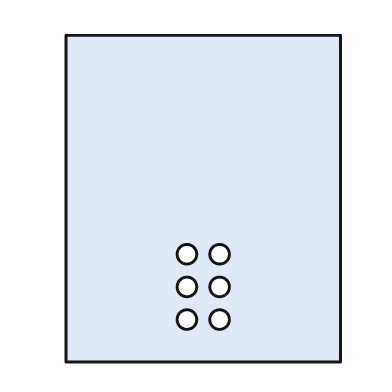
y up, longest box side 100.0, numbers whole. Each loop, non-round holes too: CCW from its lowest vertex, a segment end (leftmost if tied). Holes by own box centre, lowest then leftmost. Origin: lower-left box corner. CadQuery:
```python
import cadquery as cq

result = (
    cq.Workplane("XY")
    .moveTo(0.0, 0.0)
    .lineTo(84.0, 0.0)
    .lineTo(84.0, 100.0)
    .lineTo(0.0, 100.0)
    .close()
    .moveTo(37.0, 13.0)
    .circle(3.0)
    .moveTo(47.0, 13.0)
    .circle(3.0)
    .moveTo(37.0, 23.0)
    .circle(3.0)
    .moveTo(47.0, 23.0)
    .circle(3.0)
    .moveTo(37.0, 33.0)
    .circle(3.0)
    .moveTo(47.0, 33.0)
    .circle(3.0)
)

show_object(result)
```